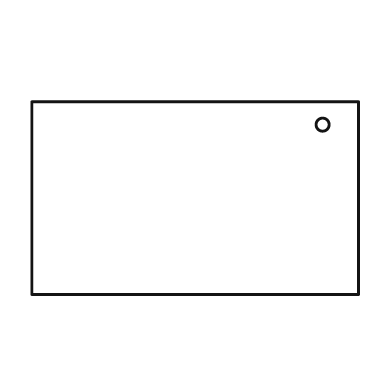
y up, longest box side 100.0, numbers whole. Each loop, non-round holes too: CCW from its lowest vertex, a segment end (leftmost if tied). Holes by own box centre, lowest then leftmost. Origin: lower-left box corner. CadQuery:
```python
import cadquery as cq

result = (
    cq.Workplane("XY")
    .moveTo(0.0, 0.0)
    .lineTo(100.0, 0.0)
    .lineTo(100.0, 59.0)
    .lineTo(0.0, 59.0)
    .close()
    .moveTo(89.0, 52.0)
    .circle(2.0)
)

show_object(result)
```